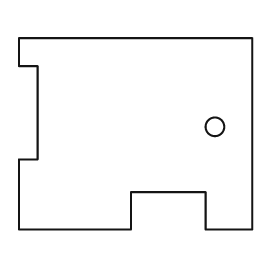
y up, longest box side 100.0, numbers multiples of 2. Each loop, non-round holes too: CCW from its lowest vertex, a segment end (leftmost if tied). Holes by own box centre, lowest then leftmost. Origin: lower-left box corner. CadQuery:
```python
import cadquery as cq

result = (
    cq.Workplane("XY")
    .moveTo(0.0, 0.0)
    .lineTo(48.0, 0.0)
    .lineTo(48.0, 16.0)
    .lineTo(80.0, 16.0)
    .lineTo(80.0, 0.0)
    .lineTo(100.0, 0.0)
    .lineTo(100.0, 82.0)
    .lineTo(0.0, 82.0)
    .lineTo(0.0, 70.0)
    .lineTo(8.0, 70.0)
    .lineTo(8.0, 30.0)
    .lineTo(0.0, 30.0)
    .close()
    .moveTo(84.0, 44.0)
    .circle(4.0)
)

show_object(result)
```